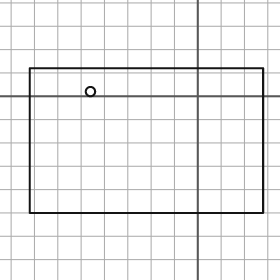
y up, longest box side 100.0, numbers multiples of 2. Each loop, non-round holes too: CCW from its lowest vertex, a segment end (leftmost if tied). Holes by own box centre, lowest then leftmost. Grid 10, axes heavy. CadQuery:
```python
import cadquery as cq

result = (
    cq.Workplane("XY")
    .moveTo(-72.0, -50.0)
    .lineTo(28.0, -50.0)
    .lineTo(28.0, 12.0)
    .lineTo(-72.0, 12.0)
    .close()
    .moveTo(-46.0, 2.0)
    .circle(2.0)
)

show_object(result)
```